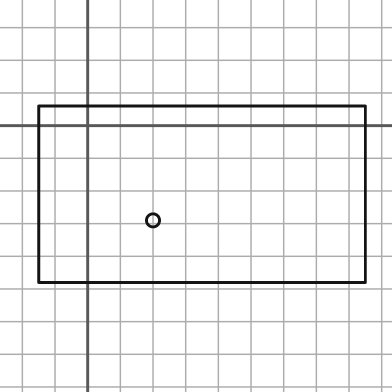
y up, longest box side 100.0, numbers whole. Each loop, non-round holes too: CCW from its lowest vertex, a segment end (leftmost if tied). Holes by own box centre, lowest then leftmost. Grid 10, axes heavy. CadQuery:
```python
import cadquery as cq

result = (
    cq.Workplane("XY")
    .moveTo(-15.0, -48.0)
    .lineTo(85.0, -48.0)
    .lineTo(85.0, 6.0)
    .lineTo(-15.0, 6.0)
    .close()
    .moveTo(20.0, -29.0)
    .circle(2.0)
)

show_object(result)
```